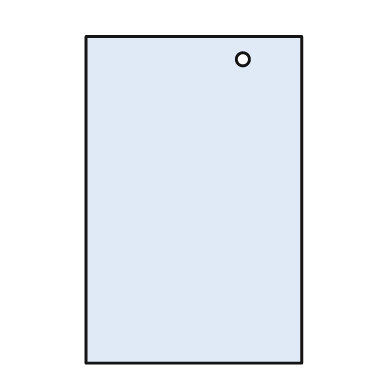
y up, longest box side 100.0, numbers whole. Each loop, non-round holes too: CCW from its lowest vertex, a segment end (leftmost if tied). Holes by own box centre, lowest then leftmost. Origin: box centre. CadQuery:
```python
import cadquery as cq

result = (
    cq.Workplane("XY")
    .moveTo(-33.0, -50.0)
    .lineTo(33.0, -50.0)
    .lineTo(33.0, 50.0)
    .lineTo(-33.0, 50.0)
    .close()
    .moveTo(15.0, 43.0)
    .circle(2.0)
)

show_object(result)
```